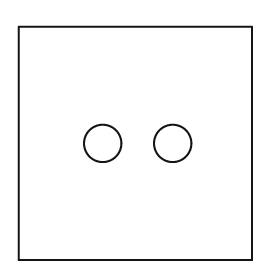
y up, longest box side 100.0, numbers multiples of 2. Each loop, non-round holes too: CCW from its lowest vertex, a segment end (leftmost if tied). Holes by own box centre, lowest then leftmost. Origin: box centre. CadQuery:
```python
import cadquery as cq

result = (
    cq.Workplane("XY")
    .moveTo(-50.0, -50.0)
    .lineTo(50.0, -50.0)
    .lineTo(50.0, 50.0)
    .lineTo(-50.0, 50.0)
    .close()
    .moveTo(-14.0, 0.0)
    .circle(8.0)
    .moveTo(16.0, 0.0)
    .circle(8.0)
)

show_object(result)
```